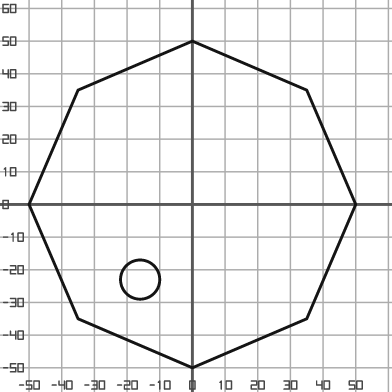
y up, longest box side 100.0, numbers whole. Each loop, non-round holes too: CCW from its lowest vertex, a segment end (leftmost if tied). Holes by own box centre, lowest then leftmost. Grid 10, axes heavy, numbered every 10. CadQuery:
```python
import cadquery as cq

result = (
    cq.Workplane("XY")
    .moveTo(0.0, -50.0)
    .lineTo(35.0, -35.0)
    .lineTo(50.0, 0.0)
    .lineTo(35.0, 35.0)
    .lineTo(0.0, 50.0)
    .lineTo(-35.0, 35.0)
    .lineTo(-50.0, 0.0)
    .lineTo(-35.0, -35.0)
    .close()
    .moveTo(-16.0, -23.0)
    .circle(6.0)
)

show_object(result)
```